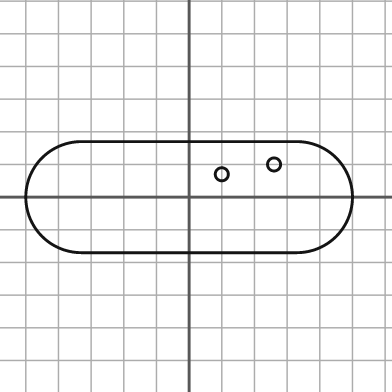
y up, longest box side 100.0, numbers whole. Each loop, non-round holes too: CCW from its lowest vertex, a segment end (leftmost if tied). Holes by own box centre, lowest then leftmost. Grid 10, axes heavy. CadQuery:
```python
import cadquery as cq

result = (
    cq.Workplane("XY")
    .moveTo(-33.0, -17.0)
    .lineTo(33.0, -17.0)
    .threePointArc((50.0, 0.0), (33.0, 17.0))
    .lineTo(-33.0, 17.0)
    .threePointArc((-50.0, 0.0), (-33.0, -17.0))
    .close()
    .moveTo(10.0, 7.0)
    .circle(2.0)
    .moveTo(26.0, 10.0)
    .circle(2.0)
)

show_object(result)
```